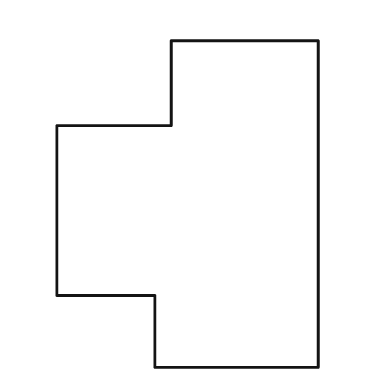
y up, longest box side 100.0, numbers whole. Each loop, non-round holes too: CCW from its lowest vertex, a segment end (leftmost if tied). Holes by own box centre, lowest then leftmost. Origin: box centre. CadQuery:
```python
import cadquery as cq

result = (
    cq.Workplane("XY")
    .moveTo(-10.0, -50.0)
    .lineTo(40.0, -50.0)
    .lineTo(40.0, 50.0)
    .lineTo(-5.0, 50.0)
    .lineTo(-5.0, 24.0)
    .lineTo(-40.0, 24.0)
    .lineTo(-40.0, -28.0)
    .lineTo(-10.0, -28.0)
    .close()
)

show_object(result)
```